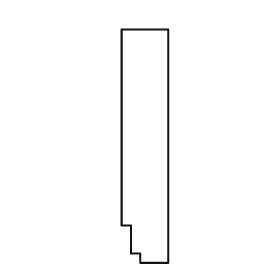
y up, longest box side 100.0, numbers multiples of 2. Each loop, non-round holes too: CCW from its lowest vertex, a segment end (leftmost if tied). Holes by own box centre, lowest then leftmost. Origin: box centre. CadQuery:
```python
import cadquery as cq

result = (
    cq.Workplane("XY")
    .moveTo(-2.0, -50.0)
    .lineTo(10.0, -50.0)
    .lineTo(10.0, 50.0)
    .lineTo(-10.0, 50.0)
    .lineTo(-10.0, -34.0)
    .lineTo(-6.0, -34.0)
    .lineTo(-6.0, -46.0)
    .lineTo(-2.0, -46.0)
    .close()
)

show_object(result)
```